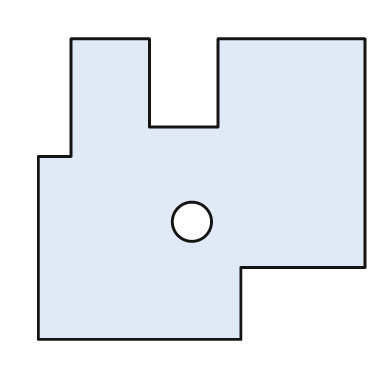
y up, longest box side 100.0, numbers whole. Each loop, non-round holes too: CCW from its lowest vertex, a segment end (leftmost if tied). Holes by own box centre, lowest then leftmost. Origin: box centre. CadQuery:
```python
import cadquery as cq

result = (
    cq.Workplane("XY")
    .moveTo(-50.0, -46.0)
    .lineTo(12.0, -46.0)
    .lineTo(12.0, -24.0)
    .lineTo(50.0, -24.0)
    .lineTo(50.0, 46.0)
    .lineTo(5.0, 46.0)
    .lineTo(5.0, 19.0)
    .lineTo(-16.0, 19.0)
    .lineTo(-16.0, 46.0)
    .lineTo(-40.0, 46.0)
    .lineTo(-40.0, 10.0)
    .lineTo(-50.0, 10.0)
    .close()
    .moveTo(-3.0, -10.0)
    .circle(6.0)
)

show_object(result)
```